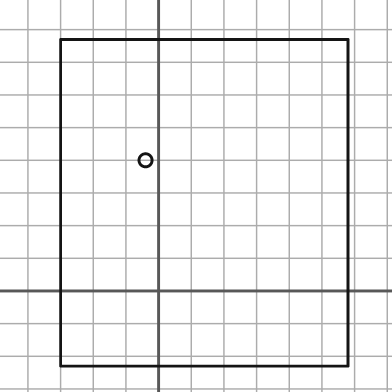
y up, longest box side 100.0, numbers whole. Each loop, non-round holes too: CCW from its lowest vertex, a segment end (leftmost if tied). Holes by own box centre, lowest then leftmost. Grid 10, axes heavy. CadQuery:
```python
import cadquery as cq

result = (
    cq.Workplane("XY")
    .moveTo(-30.0, -23.0)
    .lineTo(58.0, -23.0)
    .lineTo(58.0, 77.0)
    .lineTo(-30.0, 77.0)
    .close()
    .moveTo(-4.0, 40.0)
    .circle(2.0)
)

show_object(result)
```